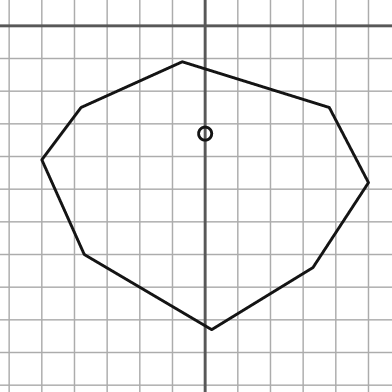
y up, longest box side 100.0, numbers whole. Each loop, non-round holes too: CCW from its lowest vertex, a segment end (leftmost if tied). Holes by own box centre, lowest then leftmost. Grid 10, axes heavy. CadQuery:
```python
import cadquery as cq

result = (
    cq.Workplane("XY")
    .moveTo(2.0, -93.0)
    .lineTo(33.0, -74.0)
    .lineTo(50.0, -48.0)
    .lineTo(38.0, -25.0)
    .lineTo(-7.0, -11.0)
    .lineTo(-38.0, -25.0)
    .lineTo(-50.0, -41.0)
    .lineTo(-37.0, -70.0)
    .close()
    .moveTo(0.0, -33.0)
    .circle(2.0)
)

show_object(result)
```